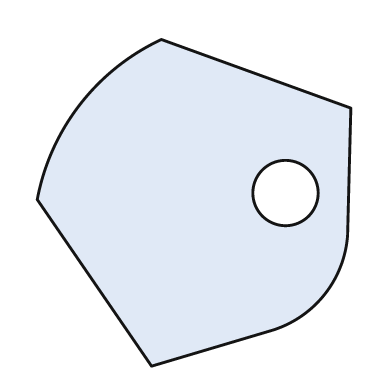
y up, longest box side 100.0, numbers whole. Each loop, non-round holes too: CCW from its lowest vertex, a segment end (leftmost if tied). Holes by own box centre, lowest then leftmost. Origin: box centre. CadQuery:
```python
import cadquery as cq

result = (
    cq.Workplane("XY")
    .moveTo(-13.0, -50.0)
    .lineTo(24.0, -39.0)
    .threePointArc((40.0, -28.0), (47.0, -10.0))
    .lineTo(48.0, 29.0)
    .lineTo(-10.0, 50.0)
    .threePointArc((-35.0, 30.0), (-48.0, 1.0))
    .close()
    .moveTo(28.0, 3.0)
    .circle(10.0)
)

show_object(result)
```